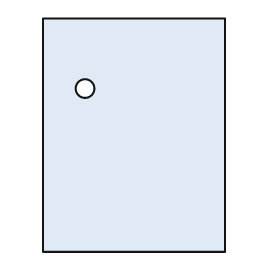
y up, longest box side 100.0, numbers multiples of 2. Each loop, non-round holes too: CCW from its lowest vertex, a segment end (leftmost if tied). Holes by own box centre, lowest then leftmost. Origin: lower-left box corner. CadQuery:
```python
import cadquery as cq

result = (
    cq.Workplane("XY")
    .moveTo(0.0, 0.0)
    .lineTo(78.0, 0.0)
    .lineTo(78.0, 100.0)
    .lineTo(0.0, 100.0)
    .close()
    .moveTo(18.0, 70.0)
    .circle(4.0)
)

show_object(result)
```